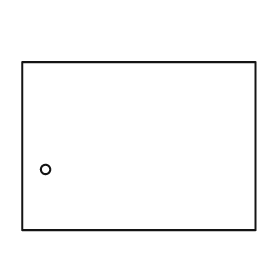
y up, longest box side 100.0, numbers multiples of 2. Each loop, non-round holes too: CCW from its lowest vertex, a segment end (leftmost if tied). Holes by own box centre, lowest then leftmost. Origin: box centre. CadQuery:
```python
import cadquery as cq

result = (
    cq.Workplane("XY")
    .moveTo(-50.0, -36.0)
    .lineTo(50.0, -36.0)
    .lineTo(50.0, 36.0)
    .lineTo(-50.0, 36.0)
    .close()
    .moveTo(-40.0, -10.0)
    .circle(2.0)
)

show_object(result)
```